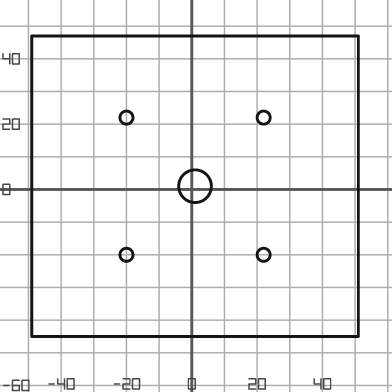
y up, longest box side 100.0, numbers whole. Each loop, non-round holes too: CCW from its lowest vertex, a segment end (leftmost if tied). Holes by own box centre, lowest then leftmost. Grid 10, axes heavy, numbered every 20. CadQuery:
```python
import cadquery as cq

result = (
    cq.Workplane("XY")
    .moveTo(-49.0, -45.0)
    .lineTo(51.0, -45.0)
    .lineTo(51.0, 47.0)
    .lineTo(-49.0, 47.0)
    .close()
    .moveTo(-20.0, -20.0)
    .circle(2.0)
    .moveTo(22.0, -20.0)
    .circle(2.0)
    .moveTo(1.0, 1.0)
    .circle(5.0)
    .moveTo(-20.0, 22.0)
    .circle(2.0)
    .moveTo(22.0, 22.0)
    .circle(2.0)
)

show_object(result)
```